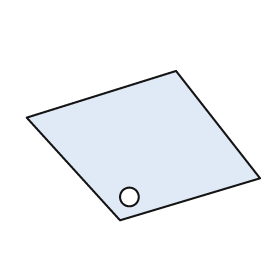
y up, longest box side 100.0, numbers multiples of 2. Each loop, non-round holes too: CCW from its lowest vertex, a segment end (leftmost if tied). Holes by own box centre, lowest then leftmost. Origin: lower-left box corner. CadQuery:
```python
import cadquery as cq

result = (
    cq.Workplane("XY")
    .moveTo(40.0, 0.0)
    .lineTo(100.0, 18.0)
    .lineTo(64.0, 64.0)
    .lineTo(0.0, 44.0)
    .close()
    .moveTo(44.0, 10.0)
    .circle(4.0)
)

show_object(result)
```